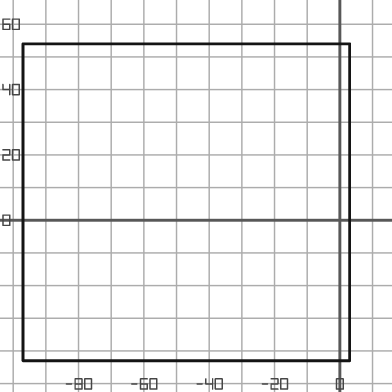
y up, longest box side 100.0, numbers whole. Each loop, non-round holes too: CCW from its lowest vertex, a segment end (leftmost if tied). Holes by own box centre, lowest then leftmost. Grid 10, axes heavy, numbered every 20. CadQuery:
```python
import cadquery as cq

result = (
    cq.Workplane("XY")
    .moveTo(-97.0, -43.0)
    .lineTo(3.0, -43.0)
    .lineTo(3.0, 54.0)
    .lineTo(-97.0, 54.0)
    .close()
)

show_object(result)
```